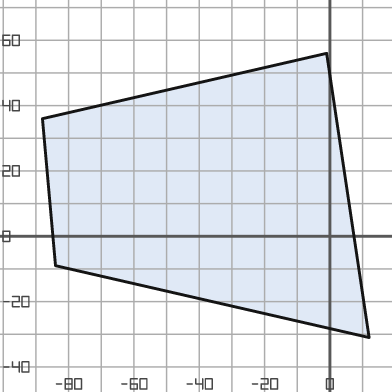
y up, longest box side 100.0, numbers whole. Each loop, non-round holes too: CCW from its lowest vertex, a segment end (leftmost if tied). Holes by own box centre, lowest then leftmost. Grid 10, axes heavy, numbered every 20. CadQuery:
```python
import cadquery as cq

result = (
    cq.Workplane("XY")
    .moveTo(12.0, -31.0)
    .lineTo(-1.0, 56.0)
    .lineTo(-88.0, 36.0)
    .lineTo(-84.0, -9.0)
    .close()
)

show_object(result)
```